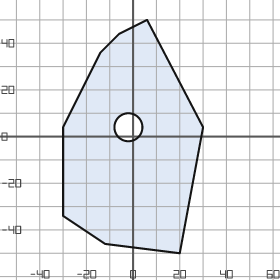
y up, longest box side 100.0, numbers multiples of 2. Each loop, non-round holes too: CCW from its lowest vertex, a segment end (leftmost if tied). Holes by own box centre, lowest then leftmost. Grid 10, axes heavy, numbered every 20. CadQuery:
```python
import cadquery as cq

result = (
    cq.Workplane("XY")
    .moveTo(20.0, -50.0)
    .lineTo(30.0, 4.0)
    .lineTo(6.0, 50.0)
    .lineTo(-6.0, 44.0)
    .lineTo(-14.0, 36.0)
    .lineTo(-30.0, 4.0)
    .lineTo(-30.0, -34.0)
    .lineTo(-12.0, -46.0)
    .close()
    .moveTo(-2.0, 4.0)
    .circle(6.0)
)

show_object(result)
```